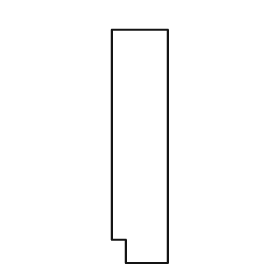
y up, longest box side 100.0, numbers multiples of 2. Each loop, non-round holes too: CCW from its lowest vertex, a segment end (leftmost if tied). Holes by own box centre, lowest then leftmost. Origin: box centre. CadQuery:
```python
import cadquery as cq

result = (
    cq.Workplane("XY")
    .moveTo(-6.0, -50.0)
    .lineTo(12.0, -50.0)
    .lineTo(12.0, 50.0)
    .lineTo(-12.0, 50.0)
    .lineTo(-12.0, -40.0)
    .lineTo(-6.0, -40.0)
    .close()
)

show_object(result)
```